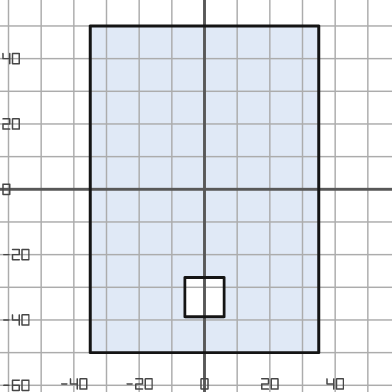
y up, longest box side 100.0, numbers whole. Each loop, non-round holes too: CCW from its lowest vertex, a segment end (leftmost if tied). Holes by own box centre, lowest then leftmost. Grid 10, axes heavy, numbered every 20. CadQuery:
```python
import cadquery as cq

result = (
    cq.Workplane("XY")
    .moveTo(-35.0, -50.0)
    .lineTo(35.0, -50.0)
    .lineTo(35.0, 50.0)
    .lineTo(-35.0, 50.0)
    .close()
    .moveTo(-6.0, -39.0)
    .lineTo(6.0, -39.0)
    .lineTo(6.0, -27.0)
    .lineTo(-6.0, -27.0)
    .close()
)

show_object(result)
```